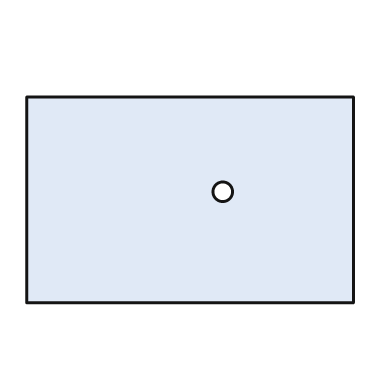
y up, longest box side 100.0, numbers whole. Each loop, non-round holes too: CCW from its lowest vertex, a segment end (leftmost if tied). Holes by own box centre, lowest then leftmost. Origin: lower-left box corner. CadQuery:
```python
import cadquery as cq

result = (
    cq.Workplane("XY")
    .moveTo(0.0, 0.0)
    .lineTo(100.0, 0.0)
    .lineTo(100.0, 63.0)
    .lineTo(0.0, 63.0)
    .close()
    .moveTo(60.0, 34.0)
    .circle(3.0)
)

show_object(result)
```